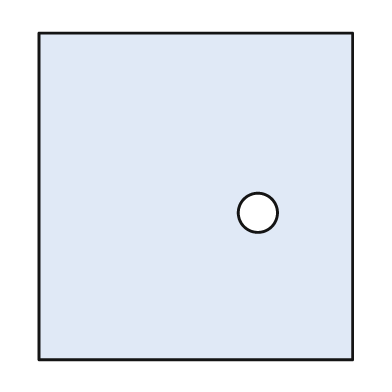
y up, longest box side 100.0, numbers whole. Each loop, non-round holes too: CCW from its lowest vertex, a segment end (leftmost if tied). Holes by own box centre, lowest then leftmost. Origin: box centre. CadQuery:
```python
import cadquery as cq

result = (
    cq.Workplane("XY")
    .moveTo(-48.0, -50.0)
    .lineTo(48.0, -50.0)
    .lineTo(48.0, 50.0)
    .lineTo(-48.0, 50.0)
    .close()
    .moveTo(19.0, -5.0)
    .circle(6.0)
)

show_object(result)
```